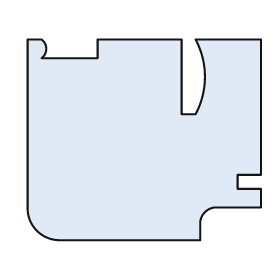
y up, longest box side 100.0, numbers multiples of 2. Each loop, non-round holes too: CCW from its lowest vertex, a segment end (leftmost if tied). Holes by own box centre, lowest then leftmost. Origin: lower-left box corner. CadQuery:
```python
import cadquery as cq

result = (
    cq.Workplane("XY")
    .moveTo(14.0, 0.0)
    .lineTo(74.0, 0.0)
    .lineTo(74.0, 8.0)
    .threePointArc((76.0, 12.0), (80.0, 14.0))
    .lineTo(100.0, 14.0)
    .lineTo(100.0, 22.0)
    .lineTo(90.0, 22.0)
    .lineTo(90.0, 28.0)
    .lineTo(100.0, 28.0)
    .lineTo(100.0, 86.0)
    .lineTo(72.0, 86.0)
    .threePointArc((76.0, 70.0), (72.0, 54.0))
    .lineTo(66.0, 54.0)
    .lineTo(66.0, 86.0)
    .lineTo(30.0, 86.0)
    .lineTo(30.0, 78.0)
    .lineTo(6.0, 78.0)
    .threePointArc((8.0, 82.0), (6.0, 86.0))
    .lineTo(0.0, 86.0)
    .lineTo(0.0, 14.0)
    .threePointArc((4.0, 4.0), (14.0, 0.0))
    .close()
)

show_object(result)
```